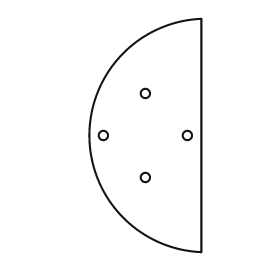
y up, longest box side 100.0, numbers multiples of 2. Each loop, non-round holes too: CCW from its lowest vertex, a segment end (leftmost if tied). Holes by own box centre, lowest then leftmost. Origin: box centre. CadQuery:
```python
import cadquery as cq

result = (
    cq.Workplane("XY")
    .moveTo(24.0, -50.0)
    .lineTo(24.0, 50.0)
    .threePointArc((-24.0, 0.0), (24.0, -50.0))
    .close()
    .moveTo(0.0, -18.0)
    .circle(2.0)
    .moveTo(-18.0, 0.0)
    .circle(2.0)
    .moveTo(18.0, 0.0)
    .circle(2.0)
    .moveTo(0.0, 18.0)
    .circle(2.0)
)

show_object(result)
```